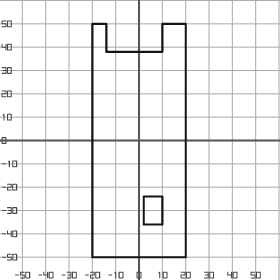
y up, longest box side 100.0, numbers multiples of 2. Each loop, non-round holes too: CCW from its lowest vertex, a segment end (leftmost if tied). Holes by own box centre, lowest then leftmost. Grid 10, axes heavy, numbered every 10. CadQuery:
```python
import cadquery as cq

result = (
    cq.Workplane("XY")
    .moveTo(-20.0, -50.0)
    .lineTo(20.0, -50.0)
    .lineTo(20.0, 50.0)
    .lineTo(10.0, 50.0)
    .lineTo(10.0, 38.0)
    .lineTo(-14.0, 38.0)
    .lineTo(-14.0, 50.0)
    .lineTo(-20.0, 50.0)
    .close()
    .moveTo(2.0, -36.0)
    .lineTo(10.0, -36.0)
    .lineTo(10.0, -24.0)
    .lineTo(2.0, -24.0)
    .close()
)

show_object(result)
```